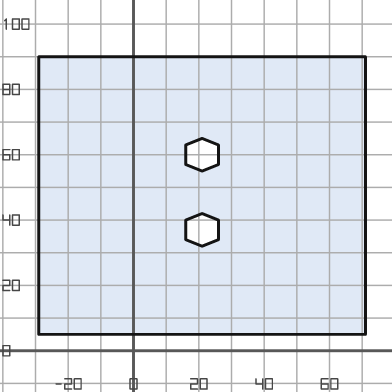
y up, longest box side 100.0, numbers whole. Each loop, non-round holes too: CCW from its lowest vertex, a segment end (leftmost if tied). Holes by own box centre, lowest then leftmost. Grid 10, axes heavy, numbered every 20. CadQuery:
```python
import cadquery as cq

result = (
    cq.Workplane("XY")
    .moveTo(-29.0, 5.0)
    .lineTo(71.0, 5.0)
    .lineTo(71.0, 90.0)
    .lineTo(-29.0, 90.0)
    .close()
    .moveTo(21.0, 32.0)
    .lineTo(26.0, 34.0)
    .lineTo(26.0, 40.0)
    .lineTo(21.0, 42.0)
    .lineTo(16.0, 40.0)
    .lineTo(16.0, 34.0)
    .close()
    .moveTo(21.0, 55.0)
    .lineTo(26.0, 57.0)
    .lineTo(26.0, 63.0)
    .lineTo(21.0, 65.0)
    .lineTo(16.0, 63.0)
    .lineTo(16.0, 57.0)
    .close()
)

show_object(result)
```